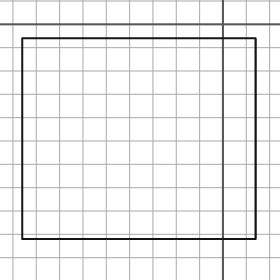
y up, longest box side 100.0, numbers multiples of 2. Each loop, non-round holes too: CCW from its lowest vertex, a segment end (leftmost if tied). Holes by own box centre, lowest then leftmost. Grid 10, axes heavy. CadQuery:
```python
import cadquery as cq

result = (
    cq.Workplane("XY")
    .moveTo(-86.0, -92.0)
    .lineTo(14.0, -92.0)
    .lineTo(14.0, -6.0)
    .lineTo(-86.0, -6.0)
    .close()
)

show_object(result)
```